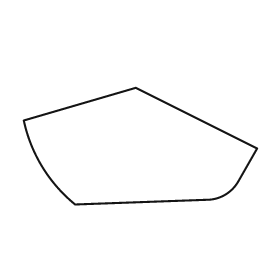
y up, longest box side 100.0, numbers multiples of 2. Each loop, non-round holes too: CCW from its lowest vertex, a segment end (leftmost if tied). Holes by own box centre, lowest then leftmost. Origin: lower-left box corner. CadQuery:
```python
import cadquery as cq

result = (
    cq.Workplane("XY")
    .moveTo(22.0, 0.0)
    .lineTo(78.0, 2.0)
    .threePointArc((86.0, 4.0), (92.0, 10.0))
    .lineTo(100.0, 24.0)
    .lineTo(48.0, 50.0)
    .lineTo(0.0, 36.0)
    .threePointArc((8.0, 16.0), (22.0, 0.0))
    .close()
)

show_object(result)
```